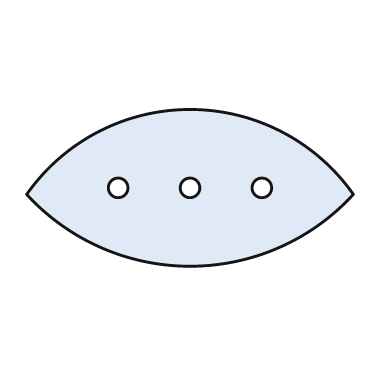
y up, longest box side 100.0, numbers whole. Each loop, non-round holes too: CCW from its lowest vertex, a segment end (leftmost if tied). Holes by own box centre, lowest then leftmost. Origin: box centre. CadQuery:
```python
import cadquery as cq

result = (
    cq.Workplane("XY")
    .moveTo(-50.0, -2.0)
    .threePointArc((0.0, -24.0), (50.0, -2.0))
    .threePointArc((0.0, 24.0), (-50.0, -2.0))
    .close()
    .moveTo(-22.0, 0.0)
    .circle(3.0)
    .moveTo(0.0, 0.0)
    .circle(3.0)
    .moveTo(22.0, 0.0)
    .circle(3.0)
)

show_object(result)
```